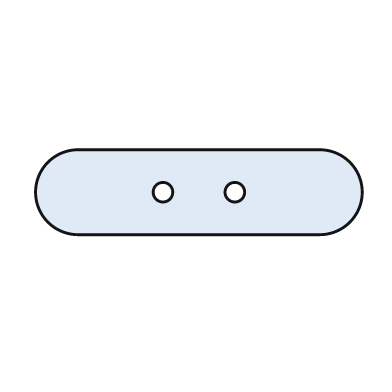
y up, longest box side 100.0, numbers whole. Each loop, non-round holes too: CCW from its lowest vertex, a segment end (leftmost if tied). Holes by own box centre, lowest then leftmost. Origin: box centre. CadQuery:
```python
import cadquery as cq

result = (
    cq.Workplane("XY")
    .moveTo(-37.0, -13.0)
    .lineTo(37.0, -13.0)
    .threePointArc((50.0, 0.0), (37.0, 13.0))
    .lineTo(-37.0, 13.0)
    .threePointArc((-50.0, 0.0), (-37.0, -13.0))
    .close()
    .moveTo(-11.0, 0.0)
    .circle(3.0)
    .moveTo(11.0, 0.0)
    .circle(3.0)
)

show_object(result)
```